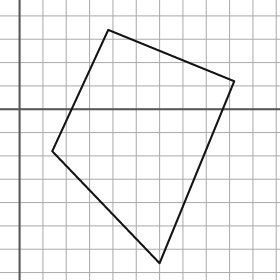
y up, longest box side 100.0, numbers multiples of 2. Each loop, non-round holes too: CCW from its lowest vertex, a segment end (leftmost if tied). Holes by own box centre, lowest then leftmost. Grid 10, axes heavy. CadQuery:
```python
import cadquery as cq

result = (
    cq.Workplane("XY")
    .moveTo(60.0, -66.0)
    .lineTo(92.0, 12.0)
    .lineTo(38.0, 34.0)
    .lineTo(14.0, -18.0)
    .close()
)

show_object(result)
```